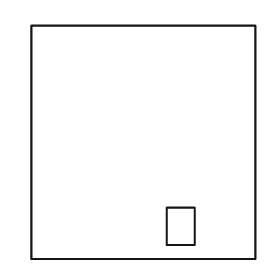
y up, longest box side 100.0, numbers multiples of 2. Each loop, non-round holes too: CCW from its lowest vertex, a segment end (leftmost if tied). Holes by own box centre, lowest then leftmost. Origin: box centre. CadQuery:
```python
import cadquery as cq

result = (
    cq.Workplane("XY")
    .moveTo(-48.0, -50.0)
    .lineTo(48.0, -50.0)
    .lineTo(48.0, 50.0)
    .lineTo(-48.0, 50.0)
    .close()
    .moveTo(10.0, -44.0)
    .lineTo(22.0, -44.0)
    .lineTo(22.0, -28.0)
    .lineTo(10.0, -28.0)
    .close()
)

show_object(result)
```